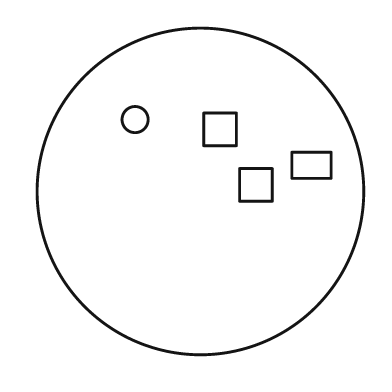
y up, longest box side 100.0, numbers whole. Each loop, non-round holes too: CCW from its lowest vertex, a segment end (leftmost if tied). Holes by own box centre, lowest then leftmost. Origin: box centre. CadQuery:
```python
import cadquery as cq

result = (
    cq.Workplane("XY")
    .moveTo(0.0, 0.0)
    .circle(50.0)
    .moveTo(12.0, -3.0)
    .lineTo(22.0, -3.0)
    .lineTo(22.0, 7.0)
    .lineTo(12.0, 7.0)
    .close()
    .moveTo(28.0, 4.0)
    .lineTo(40.0, 4.0)
    .lineTo(40.0, 12.0)
    .lineTo(28.0, 12.0)
    .close()
    .moveTo(1.0, 14.0)
    .lineTo(11.0, 14.0)
    .lineTo(11.0, 24.0)
    .lineTo(1.0, 24.0)
    .close()
    .moveTo(-20.0, 22.0)
    .circle(4.0)
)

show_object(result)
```